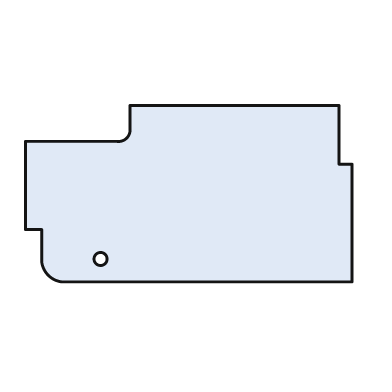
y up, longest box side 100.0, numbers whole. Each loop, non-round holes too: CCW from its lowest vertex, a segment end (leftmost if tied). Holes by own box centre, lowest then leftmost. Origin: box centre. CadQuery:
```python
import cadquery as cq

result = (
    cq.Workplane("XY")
    .moveTo(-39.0, -27.0)
    .lineTo(50.0, -27.0)
    .lineTo(50.0, 9.0)
    .lineTo(46.0, 9.0)
    .lineTo(46.0, 27.0)
    .lineTo(-18.0, 27.0)
    .lineTo(-18.0, 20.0)
    .threePointArc((-19.0, 17.0), (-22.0, 16.0))
    .lineTo(-50.0, 16.0)
    .lineTo(-50.0, -11.0)
    .lineTo(-45.0, -11.0)
    .lineTo(-45.0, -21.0)
    .threePointArc((-43.0, -25.0), (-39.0, -27.0))
    .close()
    .moveTo(-27.0, -20.0)
    .circle(2.0)
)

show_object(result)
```